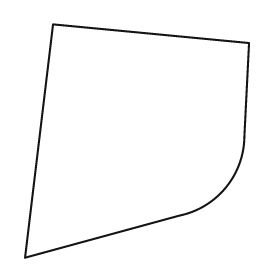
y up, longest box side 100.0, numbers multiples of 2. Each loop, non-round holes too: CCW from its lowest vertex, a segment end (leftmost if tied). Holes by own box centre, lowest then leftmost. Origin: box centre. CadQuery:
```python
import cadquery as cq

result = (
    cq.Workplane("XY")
    .moveTo(-48.0, -50.0)
    .lineTo(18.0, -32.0)
    .threePointArc((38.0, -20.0), (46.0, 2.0))
    .lineTo(48.0, 42.0)
    .lineTo(-36.0, 50.0)
    .close()
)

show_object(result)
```